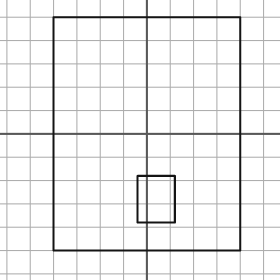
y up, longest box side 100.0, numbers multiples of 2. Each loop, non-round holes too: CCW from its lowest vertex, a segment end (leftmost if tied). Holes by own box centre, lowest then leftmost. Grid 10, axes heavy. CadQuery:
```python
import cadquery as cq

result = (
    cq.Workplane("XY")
    .moveTo(-40.0, -50.0)
    .lineTo(40.0, -50.0)
    .lineTo(40.0, 50.0)
    .lineTo(-40.0, 50.0)
    .close()
    .moveTo(-4.0, -38.0)
    .lineTo(12.0, -38.0)
    .lineTo(12.0, -18.0)
    .lineTo(-4.0, -18.0)
    .close()
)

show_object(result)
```